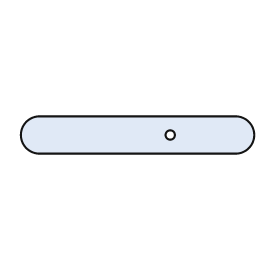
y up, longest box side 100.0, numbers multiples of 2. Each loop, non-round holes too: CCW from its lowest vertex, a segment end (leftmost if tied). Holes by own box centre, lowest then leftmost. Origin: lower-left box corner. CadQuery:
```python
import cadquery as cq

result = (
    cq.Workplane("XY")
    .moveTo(8.0, 0.0)
    .lineTo(92.0, 0.0)
    .threePointArc((100.0, 8.0), (92.0, 16.0))
    .lineTo(8.0, 16.0)
    .threePointArc((0.0, 8.0), (8.0, 0.0))
    .close()
    .moveTo(64.0, 8.0)
    .circle(2.0)
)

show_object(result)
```